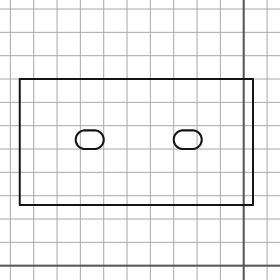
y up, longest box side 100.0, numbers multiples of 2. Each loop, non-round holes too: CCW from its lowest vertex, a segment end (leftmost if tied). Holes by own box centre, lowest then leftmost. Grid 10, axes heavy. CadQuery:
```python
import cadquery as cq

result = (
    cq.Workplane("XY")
    .moveTo(-96.0, 26.0)
    .lineTo(4.0, 26.0)
    .lineTo(4.0, 80.0)
    .lineTo(-96.0, 80.0)
    .close()
    .moveTo(-68.0, 50.0)
    .lineTo(-64.0, 50.0)
    .threePointArc((-60.0, 54.0), (-64.0, 58.0))
    .lineTo(-68.0, 58.0)
    .threePointArc((-72.0, 54.0), (-68.0, 50.0))
    .close()
    .moveTo(-26.0, 50.0)
    .lineTo(-22.0, 50.0)
    .threePointArc((-18.0, 54.0), (-22.0, 58.0))
    .lineTo(-26.0, 58.0)
    .threePointArc((-30.0, 54.0), (-26.0, 50.0))
    .close()
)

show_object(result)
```